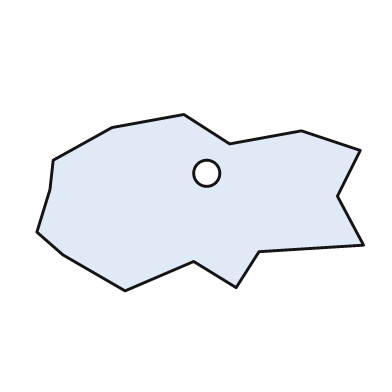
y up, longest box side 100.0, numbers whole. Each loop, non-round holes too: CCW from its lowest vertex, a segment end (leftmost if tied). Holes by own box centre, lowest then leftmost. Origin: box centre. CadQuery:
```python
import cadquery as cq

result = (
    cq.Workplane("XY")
    .moveTo(-23.0, -27.0)
    .lineTo(-2.0, -18.0)
    .lineTo(11.0, -26.0)
    .lineTo(18.0, -15.0)
    .lineTo(50.0, -13.0)
    .lineTo(42.0, 2.0)
    .lineTo(49.0, 16.0)
    .lineTo(31.0, 22.0)
    .lineTo(9.0, 18.0)
    .lineTo(-5.0, 27.0)
    .lineTo(-27.0, 23.0)
    .lineTo(-45.0, 13.0)
    .lineTo(-46.0, 4.0)
    .lineTo(-50.0, -9.0)
    .lineTo(-42.0, -16.0)
    .close()
    .moveTo(2.0, 9.0)
    .circle(4.0)
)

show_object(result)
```